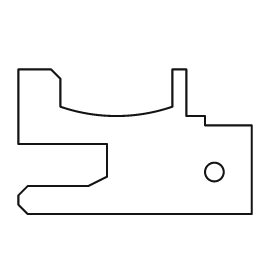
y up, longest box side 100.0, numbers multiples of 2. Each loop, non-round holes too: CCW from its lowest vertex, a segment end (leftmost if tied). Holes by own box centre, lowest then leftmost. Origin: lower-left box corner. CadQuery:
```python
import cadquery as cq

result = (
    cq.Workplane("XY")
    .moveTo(4.0, 0.0)
    .lineTo(100.0, 0.0)
    .lineTo(100.0, 38.0)
    .lineTo(80.0, 38.0)
    .lineTo(80.0, 42.0)
    .lineTo(72.0, 42.0)
    .lineTo(72.0, 62.0)
    .lineTo(66.0, 62.0)
    .lineTo(66.0, 46.0)
    .threePointArc((42.0, 42.0), (18.0, 46.0))
    .lineTo(18.0, 58.0)
    .lineTo(14.0, 62.0)
    .lineTo(0.0, 62.0)
    .lineTo(0.0, 30.0)
    .lineTo(38.0, 30.0)
    .lineTo(38.0, 16.0)
    .lineTo(30.0, 12.0)
    .lineTo(4.0, 12.0)
    .lineTo(0.0, 8.0)
    .lineTo(0.0, 4.0)
    .close()
    .moveTo(84.0, 18.0)
    .circle(4.0)
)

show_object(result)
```